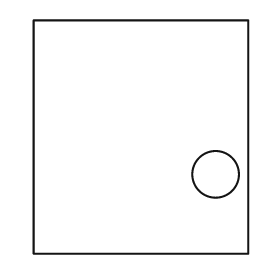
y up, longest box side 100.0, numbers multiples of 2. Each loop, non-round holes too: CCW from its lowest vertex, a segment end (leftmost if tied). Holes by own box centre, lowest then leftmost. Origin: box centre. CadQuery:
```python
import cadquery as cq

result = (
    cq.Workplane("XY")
    .moveTo(-46.0, -50.0)
    .lineTo(46.0, -50.0)
    .lineTo(46.0, 50.0)
    .lineTo(-46.0, 50.0)
    .close()
    .moveTo(32.0, -16.0)
    .circle(10.0)
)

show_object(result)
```